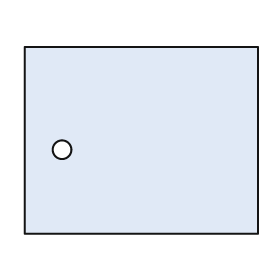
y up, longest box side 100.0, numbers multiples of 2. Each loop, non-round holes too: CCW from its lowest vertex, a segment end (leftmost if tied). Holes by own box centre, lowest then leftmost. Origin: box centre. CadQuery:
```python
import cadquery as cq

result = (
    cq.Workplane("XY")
    .moveTo(-50.0, -40.0)
    .lineTo(50.0, -40.0)
    .lineTo(50.0, 40.0)
    .lineTo(-50.0, 40.0)
    .close()
    .moveTo(-34.0, -4.0)
    .circle(4.0)
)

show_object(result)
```